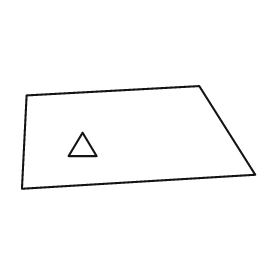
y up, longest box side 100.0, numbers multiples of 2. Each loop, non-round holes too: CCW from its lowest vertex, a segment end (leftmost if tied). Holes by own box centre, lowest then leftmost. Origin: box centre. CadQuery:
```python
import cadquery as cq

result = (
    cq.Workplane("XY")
    .moveTo(-50.0, -22.0)
    .lineTo(50.0, -16.0)
    .lineTo(26.0, 22.0)
    .lineTo(-48.0, 18.0)
    .close()
    .moveTo(-30.0, -8.0)
    .lineTo(-18.0, -8.0)
    .lineTo(-24.0, 2.0)
    .close()
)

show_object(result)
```